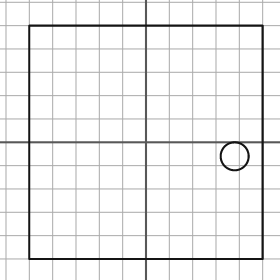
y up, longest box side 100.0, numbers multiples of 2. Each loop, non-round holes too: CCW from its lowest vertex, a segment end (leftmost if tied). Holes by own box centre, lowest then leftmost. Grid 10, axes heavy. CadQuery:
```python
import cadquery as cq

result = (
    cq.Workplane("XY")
    .moveTo(-50.0, -50.0)
    .lineTo(50.0, -50.0)
    .lineTo(50.0, 50.0)
    .lineTo(-50.0, 50.0)
    .close()
    .moveTo(38.0, -6.0)
    .circle(6.0)
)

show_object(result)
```